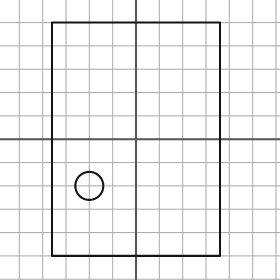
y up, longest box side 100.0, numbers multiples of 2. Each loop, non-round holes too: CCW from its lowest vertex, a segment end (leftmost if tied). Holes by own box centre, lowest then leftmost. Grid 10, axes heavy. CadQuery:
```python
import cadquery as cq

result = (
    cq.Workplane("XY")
    .moveTo(-36.0, -50.0)
    .lineTo(36.0, -50.0)
    .lineTo(36.0, 50.0)
    .lineTo(-36.0, 50.0)
    .close()
    .moveTo(-20.0, -20.0)
    .circle(6.0)
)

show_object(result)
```